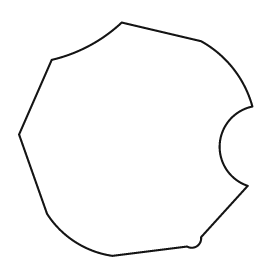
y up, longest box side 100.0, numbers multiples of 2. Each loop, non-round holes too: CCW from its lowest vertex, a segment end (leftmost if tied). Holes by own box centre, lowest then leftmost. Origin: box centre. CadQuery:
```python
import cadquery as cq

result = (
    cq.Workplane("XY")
    .moveTo(-10.0, -50.0)
    .lineTo(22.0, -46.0)
    .threePointArc((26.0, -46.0), (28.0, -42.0))
    .lineTo(48.0, -20.0)
    .threePointArc((36.0, -2.0), (50.0, 14.0))
    .threePointArc((42.0, 30.0), (28.0, 42.0))
    .lineTo(-6.0, 50.0)
    .threePointArc((-20.0, 40.0), (-36.0, 34.0))
    .lineTo(-50.0, 2.0)
    .lineTo(-38.0, -32.0)
    .threePointArc((-26.0, -44.0), (-10.0, -50.0))
    .close()
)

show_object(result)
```